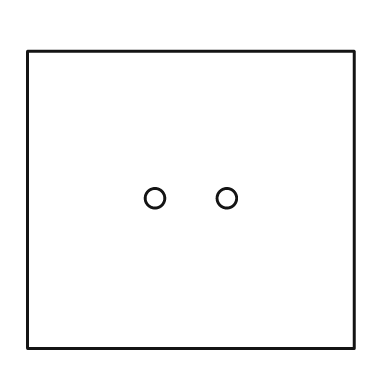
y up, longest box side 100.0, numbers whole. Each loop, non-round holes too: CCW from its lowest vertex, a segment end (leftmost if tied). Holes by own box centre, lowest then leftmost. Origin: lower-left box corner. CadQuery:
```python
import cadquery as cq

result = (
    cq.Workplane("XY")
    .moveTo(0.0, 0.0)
    .lineTo(100.0, 0.0)
    .lineTo(100.0, 91.0)
    .lineTo(0.0, 91.0)
    .close()
    .moveTo(39.0, 46.0)
    .circle(3.0)
    .moveTo(61.0, 46.0)
    .circle(3.0)
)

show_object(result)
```